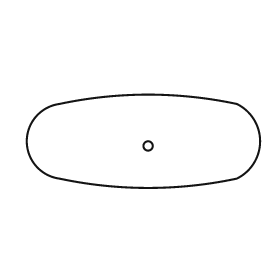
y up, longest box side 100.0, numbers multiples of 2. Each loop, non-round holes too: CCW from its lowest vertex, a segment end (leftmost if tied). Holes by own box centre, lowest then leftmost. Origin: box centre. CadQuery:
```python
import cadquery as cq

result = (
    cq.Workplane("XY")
    .moveTo(-36.0, -16.0)
    .threePointArc((2.0, -20.0), (40.0, -16.0))
    .threePointArc((50.0, 0.0), (40.0, 16.0))
    .threePointArc((2.0, 20.0), (-36.0, 16.0))
    .threePointArc((-50.0, 0.0), (-36.0, -16.0))
    .close()
    .moveTo(2.0, -2.0)
    .circle(2.0)
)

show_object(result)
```